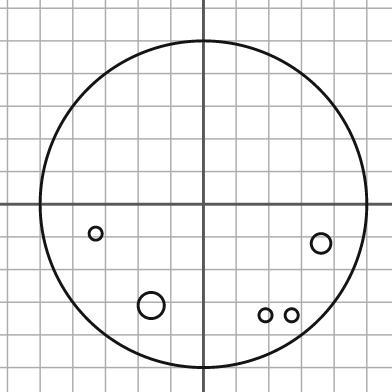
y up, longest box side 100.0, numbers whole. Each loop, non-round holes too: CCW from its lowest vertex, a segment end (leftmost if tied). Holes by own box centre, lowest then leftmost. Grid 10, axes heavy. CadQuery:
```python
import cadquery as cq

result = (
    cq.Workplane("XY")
    .moveTo(0.0, 0.0)
    .circle(50.0)
    .moveTo(19.0, -34.0)
    .circle(2.0)
    .moveTo(27.0, -34.0)
    .circle(2.0)
    .moveTo(-16.0, -31.0)
    .circle(4.0)
    .moveTo(36.0, -12.0)
    .circle(3.0)
    .moveTo(-33.0, -9.0)
    .circle(2.0)
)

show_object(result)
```